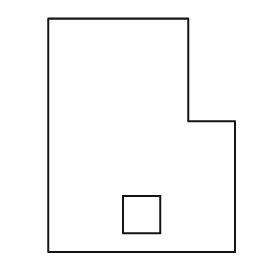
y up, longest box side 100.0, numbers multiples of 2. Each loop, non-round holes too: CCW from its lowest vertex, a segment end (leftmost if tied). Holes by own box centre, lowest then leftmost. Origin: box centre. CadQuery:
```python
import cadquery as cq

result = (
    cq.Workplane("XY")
    .moveTo(-40.0, -50.0)
    .lineTo(40.0, -50.0)
    .lineTo(40.0, 6.0)
    .lineTo(20.0, 6.0)
    .lineTo(20.0, 50.0)
    .lineTo(-40.0, 50.0)
    .close()
    .moveTo(-8.0, -42.0)
    .lineTo(8.0, -42.0)
    .lineTo(8.0, -26.0)
    .lineTo(-8.0, -26.0)
    .close()
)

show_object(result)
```